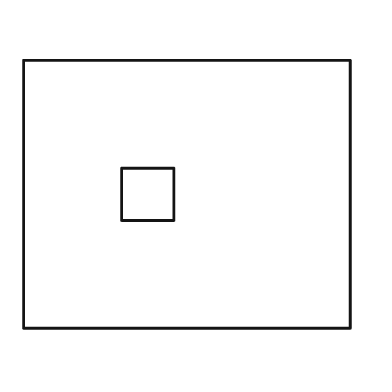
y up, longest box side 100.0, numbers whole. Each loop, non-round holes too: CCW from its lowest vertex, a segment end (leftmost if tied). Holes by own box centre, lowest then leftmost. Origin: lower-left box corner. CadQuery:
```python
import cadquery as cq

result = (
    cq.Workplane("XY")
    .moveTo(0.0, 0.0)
    .lineTo(100.0, 0.0)
    .lineTo(100.0, 82.0)
    .lineTo(0.0, 82.0)
    .close()
    .moveTo(30.0, 33.0)
    .lineTo(46.0, 33.0)
    .lineTo(46.0, 49.0)
    .lineTo(30.0, 49.0)
    .close()
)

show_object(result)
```